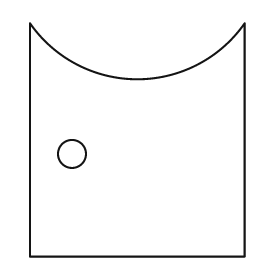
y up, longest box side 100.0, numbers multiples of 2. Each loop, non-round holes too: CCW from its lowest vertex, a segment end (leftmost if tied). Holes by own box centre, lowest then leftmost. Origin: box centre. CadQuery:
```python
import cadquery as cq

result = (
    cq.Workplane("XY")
    .moveTo(-46.0, -50.0)
    .lineTo(46.0, -50.0)
    .lineTo(46.0, 50.0)
    .threePointArc((0.0, 26.0), (-46.0, 50.0))
    .close()
    .moveTo(-28.0, -6.0)
    .circle(6.0)
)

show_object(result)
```